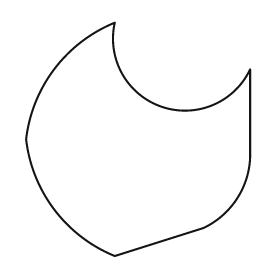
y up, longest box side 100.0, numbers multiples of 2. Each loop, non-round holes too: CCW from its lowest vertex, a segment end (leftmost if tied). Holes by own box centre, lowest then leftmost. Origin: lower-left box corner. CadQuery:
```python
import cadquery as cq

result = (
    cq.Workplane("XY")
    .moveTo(38.0, 0.0)
    .lineTo(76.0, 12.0)
    .threePointArc((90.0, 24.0), (96.0, 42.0))
    .lineTo(96.0, 80.0)
    .threePointArc((58.0, 64.0), (38.0, 100.0))
    .threePointArc((12.0, 80.0), (0.0, 50.0))
    .threePointArc((12.0, 20.0), (38.0, 0.0))
    .close()
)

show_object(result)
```